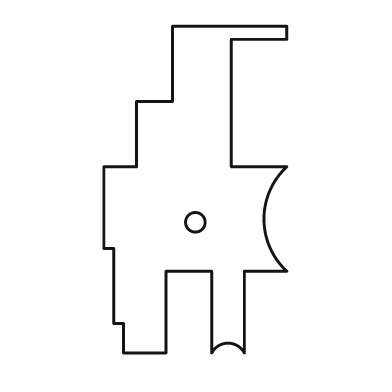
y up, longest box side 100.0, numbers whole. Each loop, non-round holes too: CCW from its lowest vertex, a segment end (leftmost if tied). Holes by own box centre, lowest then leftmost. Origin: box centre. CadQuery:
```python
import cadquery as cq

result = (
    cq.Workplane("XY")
    .moveTo(-22.0, -50.0)
    .lineTo(-9.0, -50.0)
    .lineTo(-9.0, -25.0)
    .lineTo(5.0, -25.0)
    .lineTo(5.0, -50.0)
    .threePointArc((10.0, -47.0), (15.0, -50.0))
    .lineTo(15.0, -25.0)
    .lineTo(28.0, -25.0)
    .threePointArc((21.0, -9.0), (28.0, 7.0))
    .lineTo(11.0, 7.0)
    .lineTo(11.0, 46.0)
    .lineTo(28.0, 46.0)
    .lineTo(28.0, 50.0)
    .lineTo(-7.0, 50.0)
    .lineTo(-7.0, 27.0)
    .lineTo(-18.0, 27.0)
    .lineTo(-18.0, 7.0)
    .lineTo(-28.0, 7.0)
    .lineTo(-28.0, -18.0)
    .lineTo(-25.0, -18.0)
    .lineTo(-25.0, -41.0)
    .lineTo(-22.0, -41.0)
    .close()
    .moveTo(0.0, -10.0)
    .circle(3.0)
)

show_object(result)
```